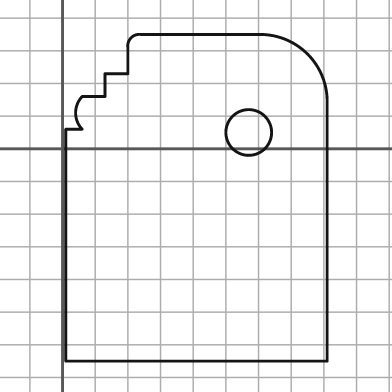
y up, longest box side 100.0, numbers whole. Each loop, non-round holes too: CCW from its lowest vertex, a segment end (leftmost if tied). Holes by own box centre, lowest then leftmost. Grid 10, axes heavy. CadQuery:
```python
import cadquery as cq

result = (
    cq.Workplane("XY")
    .moveTo(1.0, -65.0)
    .lineTo(81.0, -65.0)
    .lineTo(81.0, 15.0)
    .threePointArc((75.0, 29.0), (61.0, 35.0))
    .lineTo(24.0, 35.0)
    .threePointArc((21.0, 34.0), (20.0, 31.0))
    .lineTo(20.0, 23.0)
    .lineTo(13.0, 23.0)
    .lineTo(13.0, 16.0)
    .lineTo(6.0, 16.0)
    .threePointArc((4.0, 11.0), (6.0, 6.0))
    .lineTo(1.0, 6.0)
    .close()
    .moveTo(57.0, 5.0)
    .circle(7.0)
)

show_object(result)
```